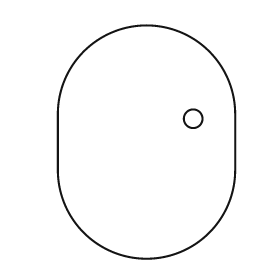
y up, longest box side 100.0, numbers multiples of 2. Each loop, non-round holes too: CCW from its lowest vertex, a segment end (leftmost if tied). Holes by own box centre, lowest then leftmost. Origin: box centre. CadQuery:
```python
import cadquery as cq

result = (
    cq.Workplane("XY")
    .moveTo(-38.0, -12.0)
    .threePointArc((0.0, -50.0), (38.0, -12.0))
    .lineTo(38.0, 12.0)
    .threePointArc((0.0, 50.0), (-38.0, 12.0))
    .close()
    .moveTo(20.0, 10.0)
    .circle(4.0)
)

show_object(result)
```